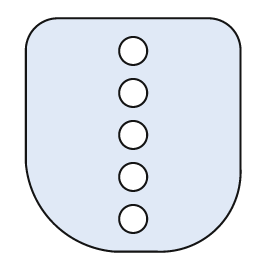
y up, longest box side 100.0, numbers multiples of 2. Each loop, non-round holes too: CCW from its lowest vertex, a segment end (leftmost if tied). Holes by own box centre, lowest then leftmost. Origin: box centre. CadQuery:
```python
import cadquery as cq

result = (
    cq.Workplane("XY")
    .moveTo(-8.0, -50.0)
    .lineTo(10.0, -50.0)
    .threePointArc((36.0, -40.0), (46.0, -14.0))
    .lineTo(46.0, 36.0)
    .threePointArc((42.0, 46.0), (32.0, 50.0))
    .lineTo(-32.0, 50.0)
    .threePointArc((-42.0, 46.0), (-46.0, 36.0))
    .lineTo(-46.0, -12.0)
    .threePointArc((-34.0, -38.0), (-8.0, -50.0))
    .close()
    .moveTo(0.0, -36.0)
    .circle(6.0)
    .moveTo(0.0, -18.0)
    .circle(6.0)
    .moveTo(0.0, 0.0)
    .circle(6.0)
    .moveTo(0.0, 18.0)
    .circle(6.0)
    .moveTo(0.0, 36.0)
    .circle(6.0)
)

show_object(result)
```